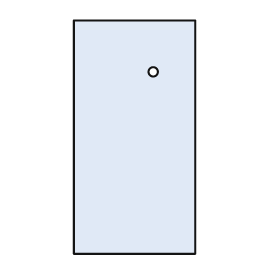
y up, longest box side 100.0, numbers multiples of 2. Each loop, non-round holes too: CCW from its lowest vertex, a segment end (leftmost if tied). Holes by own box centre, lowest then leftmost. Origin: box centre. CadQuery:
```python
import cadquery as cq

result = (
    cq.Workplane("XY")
    .moveTo(-26.0, -50.0)
    .lineTo(26.0, -50.0)
    .lineTo(26.0, 50.0)
    .lineTo(-26.0, 50.0)
    .close()
    .moveTo(8.0, 28.0)
    .circle(2.0)
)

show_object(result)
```